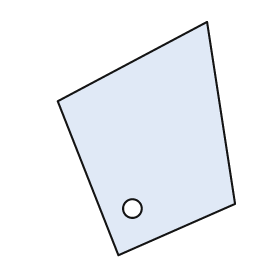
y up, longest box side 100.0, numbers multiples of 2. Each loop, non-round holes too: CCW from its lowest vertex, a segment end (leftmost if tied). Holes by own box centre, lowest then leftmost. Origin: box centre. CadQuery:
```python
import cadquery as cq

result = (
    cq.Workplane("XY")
    .moveTo(-12.0, -50.0)
    .lineTo(38.0, -28.0)
    .lineTo(26.0, 50.0)
    .lineTo(-38.0, 16.0)
    .close()
    .moveTo(-6.0, -30.0)
    .circle(4.0)
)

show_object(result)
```